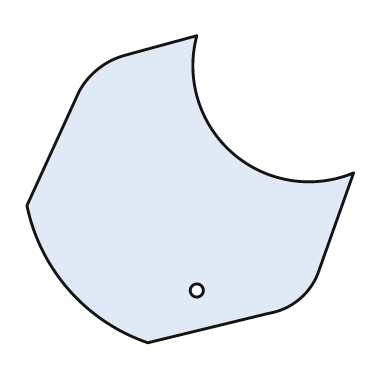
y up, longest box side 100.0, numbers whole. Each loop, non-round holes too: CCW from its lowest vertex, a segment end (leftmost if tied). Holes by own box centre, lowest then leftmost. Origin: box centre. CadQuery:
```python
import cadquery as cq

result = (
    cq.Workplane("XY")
    .moveTo(-13.0, -47.0)
    .lineTo(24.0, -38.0)
    .threePointArc((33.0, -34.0), (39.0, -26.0))
    .lineTo(50.0, 5.0)
    .threePointArc((13.0, 11.0), (2.0, 47.0))
    .lineTo(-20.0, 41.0)
    .threePointArc((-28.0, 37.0), (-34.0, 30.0))
    .lineTo(-50.0, -5.0)
    .threePointArc((-37.0, -31.0), (-13.0, -47.0))
    .close()
    .moveTo(2.0, -31.0)
    .circle(2.0)
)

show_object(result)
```